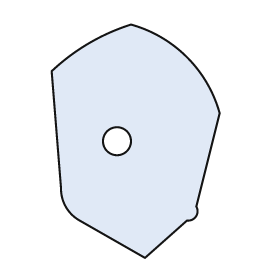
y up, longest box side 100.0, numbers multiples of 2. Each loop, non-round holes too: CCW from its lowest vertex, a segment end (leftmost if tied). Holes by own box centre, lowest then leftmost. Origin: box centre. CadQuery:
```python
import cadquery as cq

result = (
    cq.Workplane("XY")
    .moveTo(4.0, -50.0)
    .lineTo(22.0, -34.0)
    .threePointArc((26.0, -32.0), (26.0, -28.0))
    .lineTo(36.0, 12.0)
    .threePointArc((22.0, 36.0), (-2.0, 50.0))
    .threePointArc((-20.0, 42.0), (-36.0, 30.0))
    .lineTo(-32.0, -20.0)
    .threePointArc((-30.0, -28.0), (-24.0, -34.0))
    .close()
    .moveTo(-8.0, 0.0)
    .circle(6.0)
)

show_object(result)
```